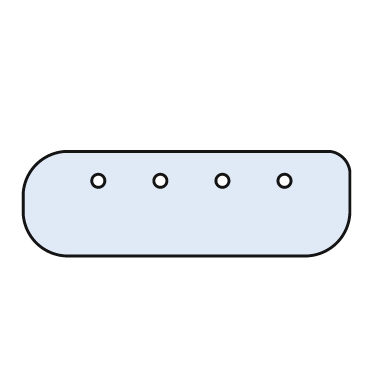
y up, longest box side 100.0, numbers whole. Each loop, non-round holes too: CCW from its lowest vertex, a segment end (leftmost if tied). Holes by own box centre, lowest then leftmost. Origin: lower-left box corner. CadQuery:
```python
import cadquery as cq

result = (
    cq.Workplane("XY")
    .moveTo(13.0, 0.0)
    .lineTo(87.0, 0.0)
    .threePointArc((96.0, 4.0), (100.0, 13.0))
    .lineTo(100.0, 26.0)
    .threePointArc((98.0, 30.0), (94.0, 32.0))
    .lineTo(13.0, 32.0)
    .threePointArc((4.0, 28.0), (0.0, 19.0))
    .lineTo(0.0, 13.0)
    .threePointArc((4.0, 4.0), (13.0, 0.0))
    .close()
    .moveTo(23.0, 23.0)
    .circle(2.0)
    .moveTo(42.0, 23.0)
    .circle(2.0)
    .moveTo(61.0, 23.0)
    .circle(2.0)
    .moveTo(80.0, 23.0)
    .circle(2.0)
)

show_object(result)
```